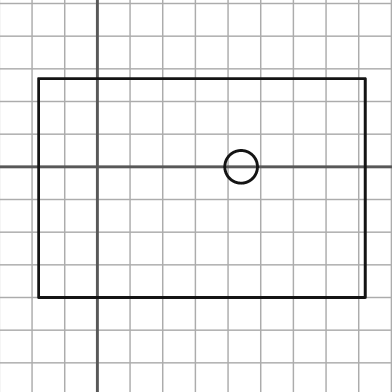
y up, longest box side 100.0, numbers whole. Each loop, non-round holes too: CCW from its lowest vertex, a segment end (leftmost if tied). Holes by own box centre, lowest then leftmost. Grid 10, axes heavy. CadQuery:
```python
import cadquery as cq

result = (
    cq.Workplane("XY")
    .moveTo(-18.0, -40.0)
    .lineTo(82.0, -40.0)
    .lineTo(82.0, 27.0)
    .lineTo(-18.0, 27.0)
    .close()
    .moveTo(44.0, 0.0)
    .circle(5.0)
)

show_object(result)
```